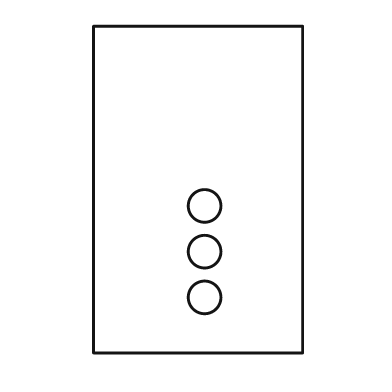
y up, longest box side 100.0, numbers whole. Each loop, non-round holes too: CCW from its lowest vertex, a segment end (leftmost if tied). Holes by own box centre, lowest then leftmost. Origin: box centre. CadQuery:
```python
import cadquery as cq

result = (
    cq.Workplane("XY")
    .moveTo(-32.0, -50.0)
    .lineTo(32.0, -50.0)
    .lineTo(32.0, 50.0)
    .lineTo(-32.0, 50.0)
    .close()
    .moveTo(2.0, -33.0)
    .circle(5.0)
    .moveTo(2.0, -19.0)
    .circle(5.0)
    .moveTo(2.0, -5.0)
    .circle(5.0)
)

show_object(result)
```